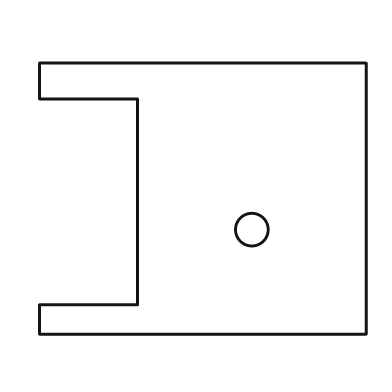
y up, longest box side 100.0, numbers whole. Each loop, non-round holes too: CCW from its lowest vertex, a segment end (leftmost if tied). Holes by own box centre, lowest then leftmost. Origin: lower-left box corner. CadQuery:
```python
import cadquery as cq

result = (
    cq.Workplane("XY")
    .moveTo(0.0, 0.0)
    .lineTo(100.0, 0.0)
    .lineTo(100.0, 83.0)
    .lineTo(0.0, 83.0)
    .lineTo(0.0, 72.0)
    .lineTo(30.0, 72.0)
    .lineTo(30.0, 9.0)
    .lineTo(0.0, 9.0)
    .close()
    .moveTo(65.0, 32.0)
    .circle(5.0)
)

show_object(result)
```